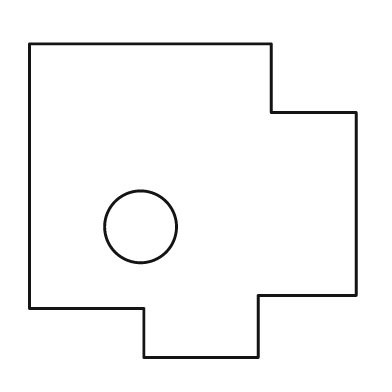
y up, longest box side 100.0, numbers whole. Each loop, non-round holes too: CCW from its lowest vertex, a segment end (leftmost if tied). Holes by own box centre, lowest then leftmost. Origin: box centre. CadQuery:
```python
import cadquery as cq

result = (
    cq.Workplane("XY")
    .moveTo(-15.0, -48.0)
    .lineTo(20.0, -48.0)
    .lineTo(20.0, -29.0)
    .lineTo(50.0, -29.0)
    .lineTo(50.0, 27.0)
    .lineTo(24.0, 27.0)
    .lineTo(24.0, 48.0)
    .lineTo(-50.0, 48.0)
    .lineTo(-50.0, -33.0)
    .lineTo(-15.0, -33.0)
    .close()
    .moveTo(-16.0, -8.0)
    .circle(11.0)
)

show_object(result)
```